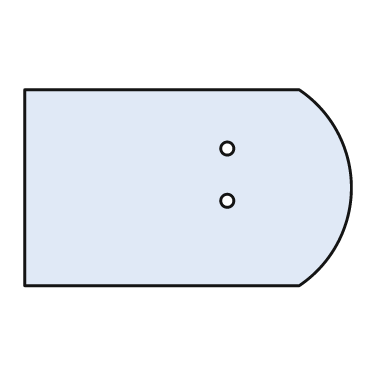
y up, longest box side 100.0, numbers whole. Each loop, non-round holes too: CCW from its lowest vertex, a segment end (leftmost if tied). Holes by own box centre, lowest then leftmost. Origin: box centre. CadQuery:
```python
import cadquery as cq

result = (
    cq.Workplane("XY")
    .moveTo(-50.0, -30.0)
    .lineTo(34.0, -30.0)
    .threePointArc((50.0, 0.0), (34.0, 30.0))
    .lineTo(-50.0, 30.0)
    .close()
    .moveTo(12.0, -4.0)
    .circle(2.0)
    .moveTo(12.0, 12.0)
    .circle(2.0)
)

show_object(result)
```